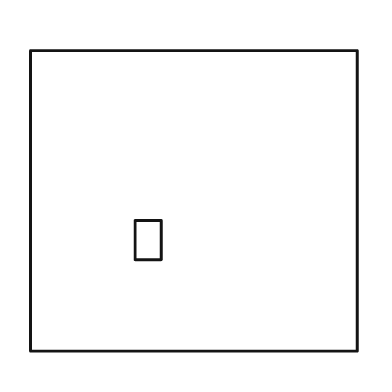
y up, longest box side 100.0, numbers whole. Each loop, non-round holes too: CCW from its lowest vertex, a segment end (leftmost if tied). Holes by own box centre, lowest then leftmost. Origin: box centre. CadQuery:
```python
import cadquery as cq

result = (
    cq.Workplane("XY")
    .moveTo(-50.0, -46.0)
    .lineTo(50.0, -46.0)
    .lineTo(50.0, 46.0)
    .lineTo(-50.0, 46.0)
    .close()
    .moveTo(-18.0, -18.0)
    .lineTo(-10.0, -18.0)
    .lineTo(-10.0, -6.0)
    .lineTo(-18.0, -6.0)
    .close()
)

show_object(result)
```